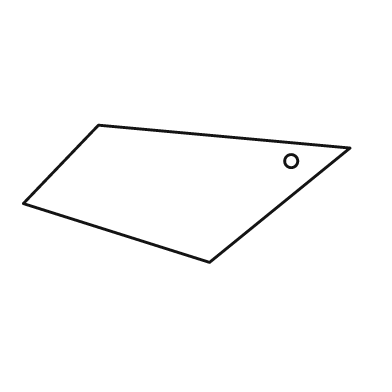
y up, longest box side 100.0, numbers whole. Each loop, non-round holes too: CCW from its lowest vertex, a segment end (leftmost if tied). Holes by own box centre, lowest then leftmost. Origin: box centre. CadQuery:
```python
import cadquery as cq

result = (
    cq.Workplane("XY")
    .moveTo(7.0, -21.0)
    .lineTo(50.0, 14.0)
    .lineTo(-27.0, 21.0)
    .lineTo(-50.0, -3.0)
    .close()
    .moveTo(32.0, 10.0)
    .circle(2.0)
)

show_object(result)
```